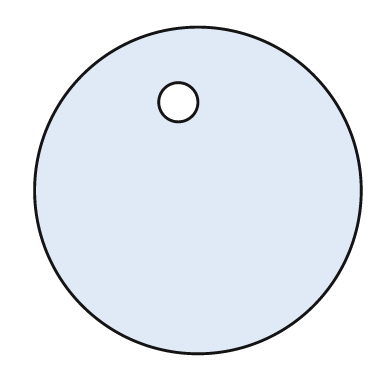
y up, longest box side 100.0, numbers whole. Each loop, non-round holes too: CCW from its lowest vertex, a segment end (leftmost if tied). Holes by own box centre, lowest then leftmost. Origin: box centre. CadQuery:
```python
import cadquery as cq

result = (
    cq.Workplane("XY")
    .moveTo(0.0, 0.0)
    .circle(50.0)
    .moveTo(-6.0, 27.0)
    .circle(6.0)
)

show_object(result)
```